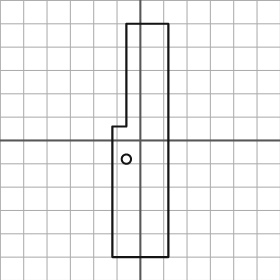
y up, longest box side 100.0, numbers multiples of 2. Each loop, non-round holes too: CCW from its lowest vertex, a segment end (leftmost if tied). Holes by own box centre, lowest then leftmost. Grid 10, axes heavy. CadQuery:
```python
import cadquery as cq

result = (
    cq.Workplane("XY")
    .moveTo(-12.0, -50.0)
    .lineTo(12.0, -50.0)
    .lineTo(12.0, 50.0)
    .lineTo(-6.0, 50.0)
    .lineTo(-6.0, 6.0)
    .lineTo(-12.0, 6.0)
    .close()
    .moveTo(-6.0, -8.0)
    .circle(2.0)
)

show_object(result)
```